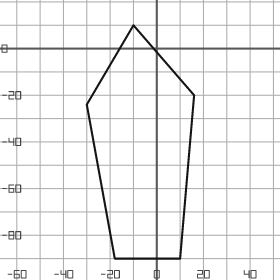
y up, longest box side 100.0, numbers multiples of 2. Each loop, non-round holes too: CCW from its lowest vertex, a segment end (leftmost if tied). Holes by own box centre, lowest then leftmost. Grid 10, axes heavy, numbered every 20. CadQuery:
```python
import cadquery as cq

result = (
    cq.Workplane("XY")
    .moveTo(-18.0, -90.0)
    .lineTo(10.0, -90.0)
    .lineTo(16.0, -20.0)
    .lineTo(-10.0, 10.0)
    .lineTo(-30.0, -24.0)
    .close()
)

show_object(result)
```